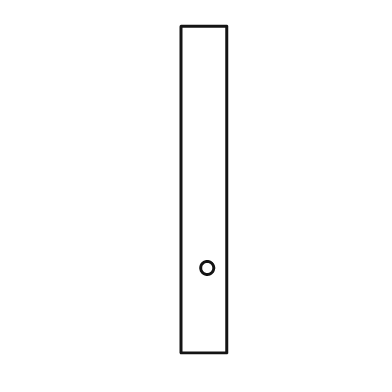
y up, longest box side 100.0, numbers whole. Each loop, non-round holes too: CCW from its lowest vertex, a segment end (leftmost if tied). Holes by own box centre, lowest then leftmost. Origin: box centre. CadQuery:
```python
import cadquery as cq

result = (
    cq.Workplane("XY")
    .moveTo(-7.0, -50.0)
    .lineTo(7.0, -50.0)
    .lineTo(7.0, 50.0)
    .lineTo(-7.0, 50.0)
    .close()
    .moveTo(1.0, -24.0)
    .circle(2.0)
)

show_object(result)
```